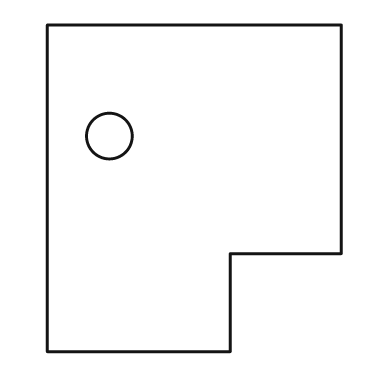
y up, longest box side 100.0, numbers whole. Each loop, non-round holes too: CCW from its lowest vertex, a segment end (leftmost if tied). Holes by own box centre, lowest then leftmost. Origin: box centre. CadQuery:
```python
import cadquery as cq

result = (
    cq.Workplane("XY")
    .moveTo(-45.0, -50.0)
    .lineTo(11.0, -50.0)
    .lineTo(11.0, -20.0)
    .lineTo(45.0, -20.0)
    .lineTo(45.0, 50.0)
    .lineTo(-45.0, 50.0)
    .close()
    .moveTo(-26.0, 16.0)
    .circle(7.0)
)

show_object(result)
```